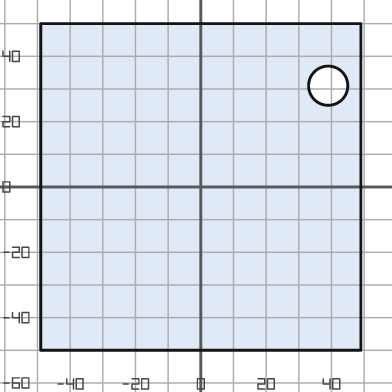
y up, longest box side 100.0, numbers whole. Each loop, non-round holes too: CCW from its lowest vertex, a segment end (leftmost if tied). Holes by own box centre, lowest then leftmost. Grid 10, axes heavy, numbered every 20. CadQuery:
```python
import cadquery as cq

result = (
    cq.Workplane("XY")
    .moveTo(-49.0, -50.0)
    .lineTo(49.0, -50.0)
    .lineTo(49.0, 50.0)
    .lineTo(-49.0, 50.0)
    .close()
    .moveTo(39.0, 31.0)
    .circle(6.0)
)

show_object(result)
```